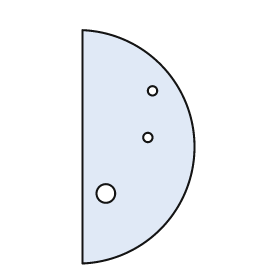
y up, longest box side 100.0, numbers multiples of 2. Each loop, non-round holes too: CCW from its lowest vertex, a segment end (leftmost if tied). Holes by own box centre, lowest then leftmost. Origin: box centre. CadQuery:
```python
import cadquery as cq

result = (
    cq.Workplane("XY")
    .moveTo(-24.0, -50.0)
    .threePointArc((24.0, 0.0), (-24.0, 50.0))
    .close()
    .moveTo(-14.0, -20.0)
    .circle(4.0)
    .moveTo(4.0, 4.0)
    .circle(2.0)
    .moveTo(6.0, 24.0)
    .circle(2.0)
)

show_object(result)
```